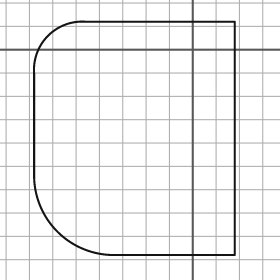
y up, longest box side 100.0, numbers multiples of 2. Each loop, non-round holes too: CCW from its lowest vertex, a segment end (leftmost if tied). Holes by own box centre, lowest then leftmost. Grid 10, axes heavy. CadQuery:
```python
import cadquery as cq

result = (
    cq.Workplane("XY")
    .moveTo(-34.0, -88.0)
    .lineTo(18.0, -88.0)
    .lineTo(18.0, 12.0)
    .lineTo(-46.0, 12.0)
    .threePointArc((-62.0, 6.0), (-68.0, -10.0))
    .lineTo(-68.0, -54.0)
    .threePointArc((-58.0, -78.0), (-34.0, -88.0))
    .close()
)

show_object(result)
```